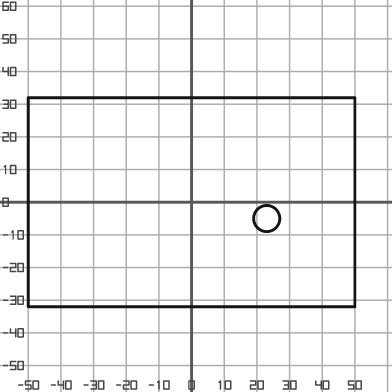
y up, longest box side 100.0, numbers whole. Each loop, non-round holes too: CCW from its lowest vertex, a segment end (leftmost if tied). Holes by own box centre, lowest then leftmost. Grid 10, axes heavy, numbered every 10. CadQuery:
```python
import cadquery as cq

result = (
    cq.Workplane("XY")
    .moveTo(-50.0, -32.0)
    .lineTo(50.0, -32.0)
    .lineTo(50.0, 32.0)
    .lineTo(-50.0, 32.0)
    .close()
    .moveTo(23.0, -5.0)
    .circle(4.0)
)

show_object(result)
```